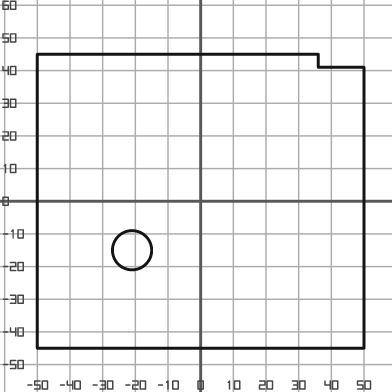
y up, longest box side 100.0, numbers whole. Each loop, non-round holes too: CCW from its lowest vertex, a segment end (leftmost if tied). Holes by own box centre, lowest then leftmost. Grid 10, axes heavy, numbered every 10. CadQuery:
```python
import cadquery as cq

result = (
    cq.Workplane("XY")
    .moveTo(-50.0, -45.0)
    .lineTo(50.0, -45.0)
    .lineTo(50.0, 41.0)
    .lineTo(36.0, 41.0)
    .lineTo(36.0, 45.0)
    .lineTo(-50.0, 45.0)
    .close()
    .moveTo(-21.0, -15.0)
    .circle(6.0)
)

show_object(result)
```